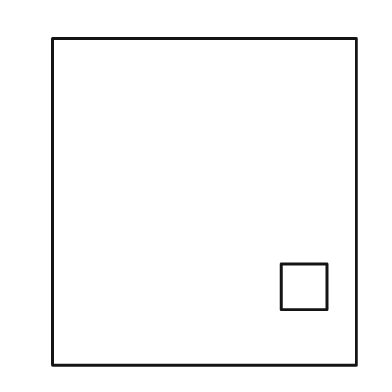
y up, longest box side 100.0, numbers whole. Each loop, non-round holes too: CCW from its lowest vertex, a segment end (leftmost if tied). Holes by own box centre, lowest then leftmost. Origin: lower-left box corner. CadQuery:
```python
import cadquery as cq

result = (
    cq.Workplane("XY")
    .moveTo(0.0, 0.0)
    .lineTo(93.0, 0.0)
    .lineTo(93.0, 100.0)
    .lineTo(0.0, 100.0)
    .close()
    .moveTo(70.0, 17.0)
    .lineTo(84.0, 17.0)
    .lineTo(84.0, 31.0)
    .lineTo(70.0, 31.0)
    .close()
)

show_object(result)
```